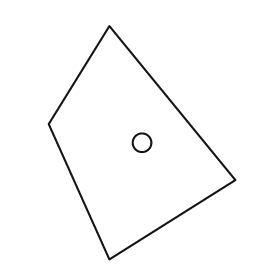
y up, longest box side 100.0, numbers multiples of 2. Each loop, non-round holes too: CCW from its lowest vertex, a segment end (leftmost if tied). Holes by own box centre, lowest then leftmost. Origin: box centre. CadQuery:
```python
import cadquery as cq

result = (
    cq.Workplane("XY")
    .moveTo(-14.0, -50.0)
    .lineTo(40.0, -16.0)
    .lineTo(-14.0, 50.0)
    .lineTo(-40.0, 8.0)
    .close()
    .moveTo(0.0, 0.0)
    .circle(4.0)
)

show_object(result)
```